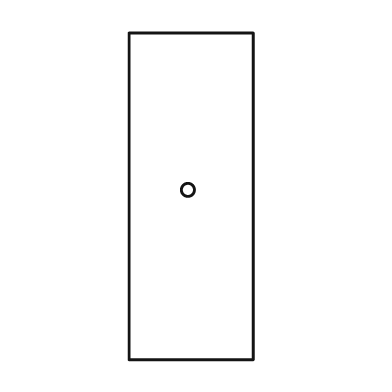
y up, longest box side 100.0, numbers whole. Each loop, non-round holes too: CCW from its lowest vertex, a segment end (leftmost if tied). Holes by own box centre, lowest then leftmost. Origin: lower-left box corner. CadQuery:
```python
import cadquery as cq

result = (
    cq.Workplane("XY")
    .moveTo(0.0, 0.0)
    .lineTo(38.0, 0.0)
    .lineTo(38.0, 100.0)
    .lineTo(0.0, 100.0)
    .close()
    .moveTo(18.0, 52.0)
    .circle(2.0)
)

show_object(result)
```